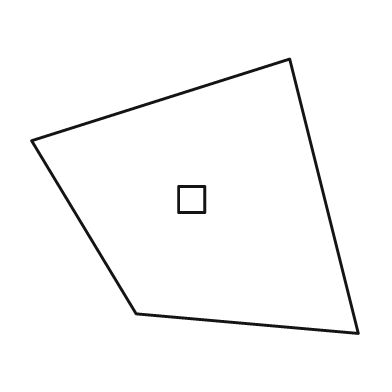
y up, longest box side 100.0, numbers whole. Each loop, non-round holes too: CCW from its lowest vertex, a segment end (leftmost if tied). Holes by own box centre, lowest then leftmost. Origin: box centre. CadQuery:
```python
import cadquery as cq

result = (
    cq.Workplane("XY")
    .moveTo(50.0, -42.0)
    .lineTo(29.0, 42.0)
    .lineTo(-50.0, 17.0)
    .lineTo(-18.0, -36.0)
    .close()
    .moveTo(-5.0, -5.0)
    .lineTo(3.0, -5.0)
    .lineTo(3.0, 3.0)
    .lineTo(-5.0, 3.0)
    .close()
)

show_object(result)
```